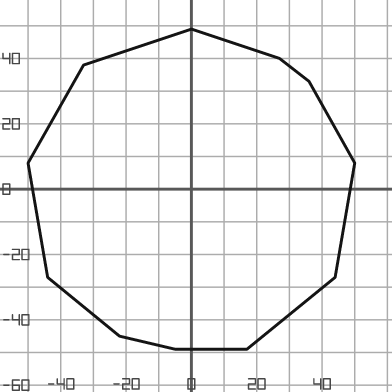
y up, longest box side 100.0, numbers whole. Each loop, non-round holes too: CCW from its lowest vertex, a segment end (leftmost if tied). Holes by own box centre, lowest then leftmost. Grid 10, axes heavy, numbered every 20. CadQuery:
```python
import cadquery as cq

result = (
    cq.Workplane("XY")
    .moveTo(-5.0, -49.0)
    .lineTo(17.0, -49.0)
    .lineTo(44.0, -27.0)
    .lineTo(50.0, 8.0)
    .lineTo(36.0, 33.0)
    .lineTo(27.0, 40.0)
    .lineTo(0.0, 49.0)
    .lineTo(-33.0, 38.0)
    .lineTo(-50.0, 8.0)
    .lineTo(-44.0, -27.0)
    .lineTo(-22.0, -45.0)
    .close()
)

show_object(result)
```